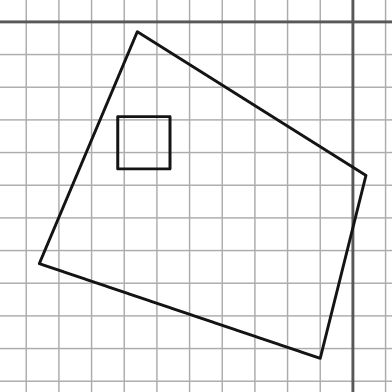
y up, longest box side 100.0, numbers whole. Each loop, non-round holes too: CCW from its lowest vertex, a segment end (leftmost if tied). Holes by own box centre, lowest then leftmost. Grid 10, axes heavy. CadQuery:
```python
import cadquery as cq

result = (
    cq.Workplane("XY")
    .moveTo(-10.0, -103.0)
    .lineTo(4.0, -47.0)
    .lineTo(-66.0, -3.0)
    .lineTo(-96.0, -74.0)
    .close()
    .moveTo(-72.0, -45.0)
    .lineTo(-56.0, -45.0)
    .lineTo(-56.0, -29.0)
    .lineTo(-72.0, -29.0)
    .close()
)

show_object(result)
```